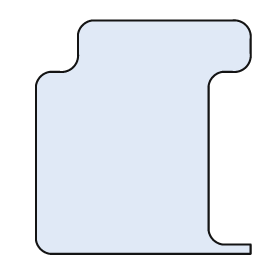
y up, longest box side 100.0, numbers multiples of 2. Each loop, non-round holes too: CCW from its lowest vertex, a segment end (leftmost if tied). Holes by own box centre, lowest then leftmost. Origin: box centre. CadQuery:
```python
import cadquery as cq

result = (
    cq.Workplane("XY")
    .moveTo(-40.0, -50.0)
    .lineTo(46.0, -50.0)
    .lineTo(46.0, -46.0)
    .lineTo(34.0, -46.0)
    .threePointArc((30.0, -44.0), (28.0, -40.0))
    .lineTo(28.0, 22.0)
    .threePointArc((30.0, 26.0), (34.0, 28.0))
    .lineTo(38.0, 28.0)
    .threePointArc((44.0, 30.0), (46.0, 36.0))
    .lineTo(46.0, 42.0)
    .threePointArc((44.0, 48.0), (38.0, 50.0))
    .lineTo(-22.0, 50.0)
    .threePointArc((-26.0, 48.0), (-28.0, 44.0))
    .lineTo(-28.0, 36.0)
    .threePointArc((-30.0, 30.0), (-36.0, 28.0))
    .lineTo(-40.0, 28.0)
    .threePointArc((-44.0, 26.0), (-46.0, 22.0))
    .lineTo(-46.0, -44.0)
    .threePointArc((-44.0, -48.0), (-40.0, -50.0))
    .close()
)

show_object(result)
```